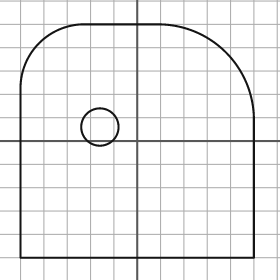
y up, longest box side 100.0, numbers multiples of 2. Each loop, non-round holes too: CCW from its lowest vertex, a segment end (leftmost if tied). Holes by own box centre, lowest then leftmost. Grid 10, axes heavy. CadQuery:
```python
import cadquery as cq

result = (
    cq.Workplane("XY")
    .moveTo(-50.0, -50.0)
    .lineTo(50.0, -50.0)
    .lineTo(50.0, 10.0)
    .threePointArc((38.0, 38.0), (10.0, 50.0))
    .lineTo(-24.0, 50.0)
    .threePointArc((-42.0, 42.0), (-50.0, 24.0))
    .close()
    .moveTo(-16.0, 6.0)
    .circle(8.0)
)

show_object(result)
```